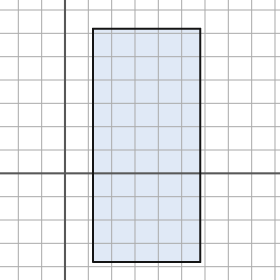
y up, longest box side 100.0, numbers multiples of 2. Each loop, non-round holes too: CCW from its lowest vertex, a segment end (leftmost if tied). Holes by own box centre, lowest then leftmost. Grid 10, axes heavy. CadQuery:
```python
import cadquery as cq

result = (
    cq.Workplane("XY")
    .moveTo(12.0, -38.0)
    .lineTo(58.0, -38.0)
    .lineTo(58.0, 62.0)
    .lineTo(12.0, 62.0)
    .close()
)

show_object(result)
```